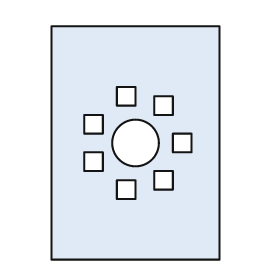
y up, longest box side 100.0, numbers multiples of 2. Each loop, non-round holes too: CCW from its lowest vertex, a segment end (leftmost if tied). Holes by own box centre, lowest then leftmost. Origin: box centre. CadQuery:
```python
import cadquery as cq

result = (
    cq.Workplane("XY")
    .moveTo(-36.0, -50.0)
    .lineTo(36.0, -50.0)
    .lineTo(36.0, 50.0)
    .lineTo(-36.0, 50.0)
    .close()
    .moveTo(-8.0, -24.0)
    .lineTo(0.0, -24.0)
    .lineTo(0.0, -16.0)
    .lineTo(-8.0, -16.0)
    .close()
    .moveTo(8.0, -20.0)
    .lineTo(16.0, -20.0)
    .lineTo(16.0, -12.0)
    .lineTo(8.0, -12.0)
    .close()
    .moveTo(-22.0, -12.0)
    .lineTo(-14.0, -12.0)
    .lineTo(-14.0, -4.0)
    .lineTo(-22.0, -4.0)
    .close()
    .moveTo(0.0, 0.0)
    .circle(10.0)
    .moveTo(16.0, -4.0)
    .lineTo(24.0, -4.0)
    .lineTo(24.0, 4.0)
    .lineTo(16.0, 4.0)
    .close()
    .moveTo(-22.0, 4.0)
    .lineTo(-14.0, 4.0)
    .lineTo(-14.0, 12.0)
    .lineTo(-22.0, 12.0)
    .close()
    .moveTo(8.0, 12.0)
    .lineTo(16.0, 12.0)
    .lineTo(16.0, 20.0)
    .lineTo(8.0, 20.0)
    .close()
    .moveTo(-8.0, 16.0)
    .lineTo(0.0, 16.0)
    .lineTo(0.0, 24.0)
    .lineTo(-8.0, 24.0)
    .close()
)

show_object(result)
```